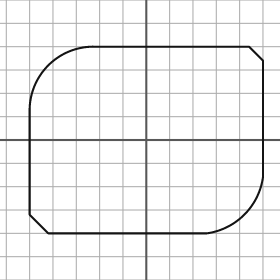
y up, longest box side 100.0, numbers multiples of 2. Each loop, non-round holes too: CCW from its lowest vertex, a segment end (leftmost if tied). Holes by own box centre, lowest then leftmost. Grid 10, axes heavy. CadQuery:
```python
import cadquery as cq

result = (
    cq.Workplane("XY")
    .moveTo(-42.0, -40.0)
    .lineTo(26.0, -40.0)
    .threePointArc((42.0, -32.0), (50.0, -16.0))
    .lineTo(50.0, 34.0)
    .lineTo(44.0, 40.0)
    .lineTo(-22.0, 40.0)
    .threePointArc((-42.0, 32.0), (-50.0, 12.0))
    .lineTo(-50.0, -32.0)
    .close()
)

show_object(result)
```